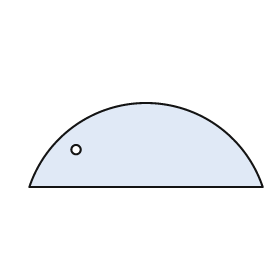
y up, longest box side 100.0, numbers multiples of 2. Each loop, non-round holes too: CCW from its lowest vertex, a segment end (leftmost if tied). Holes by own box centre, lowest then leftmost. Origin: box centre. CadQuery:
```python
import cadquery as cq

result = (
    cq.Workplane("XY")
    .moveTo(-50.0, -18.0)
    .lineTo(50.0, -18.0)
    .threePointArc((0.0, 18.0), (-50.0, -18.0))
    .close()
    .moveTo(-30.0, -2.0)
    .circle(2.0)
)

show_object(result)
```